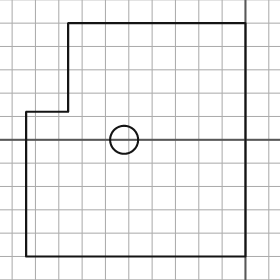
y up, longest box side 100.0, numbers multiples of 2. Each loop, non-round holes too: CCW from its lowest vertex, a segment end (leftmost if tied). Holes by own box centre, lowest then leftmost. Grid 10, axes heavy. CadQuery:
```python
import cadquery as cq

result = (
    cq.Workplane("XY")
    .moveTo(-94.0, -50.0)
    .lineTo(0.0, -50.0)
    .lineTo(0.0, 50.0)
    .lineTo(-76.0, 50.0)
    .lineTo(-76.0, 12.0)
    .lineTo(-94.0, 12.0)
    .close()
    .moveTo(-52.0, 0.0)
    .circle(6.0)
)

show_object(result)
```